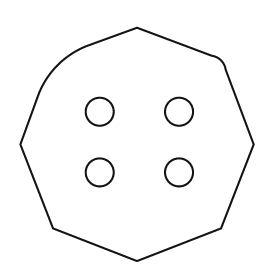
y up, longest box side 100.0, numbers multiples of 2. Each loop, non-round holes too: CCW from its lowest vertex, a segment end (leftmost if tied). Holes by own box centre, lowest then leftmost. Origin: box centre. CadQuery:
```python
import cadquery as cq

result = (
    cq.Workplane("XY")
    .moveTo(0.0, -50.0)
    .lineTo(36.0, -36.0)
    .lineTo(50.0, 0.0)
    .lineTo(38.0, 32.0)
    .threePointArc((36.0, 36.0), (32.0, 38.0))
    .lineTo(0.0, 50.0)
    .lineTo(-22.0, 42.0)
    .threePointArc((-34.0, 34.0), (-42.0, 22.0))
    .lineTo(-50.0, 0.0)
    .lineTo(-36.0, -36.0)
    .close()
    .moveTo(-16.0, -12.0)
    .circle(6.0)
    .moveTo(18.0, -12.0)
    .circle(6.0)
    .moveTo(-16.0, 14.0)
    .circle(6.0)
    .moveTo(18.0, 14.0)
    .circle(6.0)
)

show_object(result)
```